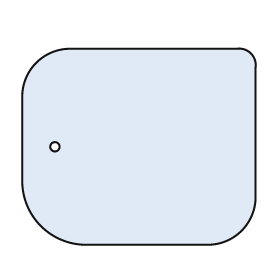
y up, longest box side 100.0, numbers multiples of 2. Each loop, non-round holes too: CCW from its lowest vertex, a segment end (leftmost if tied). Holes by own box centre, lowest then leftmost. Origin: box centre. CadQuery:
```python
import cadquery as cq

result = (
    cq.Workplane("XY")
    .moveTo(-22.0, -42.0)
    .lineTo(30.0, -42.0)
    .threePointArc((44.0, -36.0), (50.0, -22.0))
    .lineTo(50.0, 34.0)
    .threePointArc((48.0, 40.0), (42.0, 42.0))
    .lineTo(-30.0, 42.0)
    .threePointArc((-44.0, 36.0), (-50.0, 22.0))
    .lineTo(-50.0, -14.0)
    .threePointArc((-42.0, -34.0), (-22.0, -42.0))
    .close()
    .moveTo(-36.0, 0.0)
    .circle(2.0)
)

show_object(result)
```